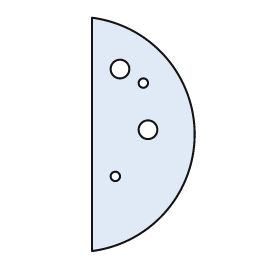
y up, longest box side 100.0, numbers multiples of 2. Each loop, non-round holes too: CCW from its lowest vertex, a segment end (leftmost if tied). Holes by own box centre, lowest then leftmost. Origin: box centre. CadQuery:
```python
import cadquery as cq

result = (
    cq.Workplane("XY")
    .moveTo(-22.0, -50.0)
    .threePointArc((22.0, 0.0), (-22.0, 50.0))
    .close()
    .moveTo(-12.0, -18.0)
    .circle(2.0)
    .moveTo(2.0, 2.0)
    .circle(4.0)
    .moveTo(0.0, 22.0)
    .circle(2.0)
    .moveTo(-10.0, 28.0)
    .circle(4.0)
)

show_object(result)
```